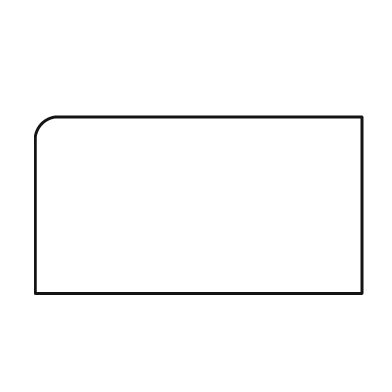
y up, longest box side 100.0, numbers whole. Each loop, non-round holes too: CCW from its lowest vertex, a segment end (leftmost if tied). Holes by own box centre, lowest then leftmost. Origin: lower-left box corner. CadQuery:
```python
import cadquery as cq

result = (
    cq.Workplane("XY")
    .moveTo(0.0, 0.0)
    .lineTo(100.0, 0.0)
    .lineTo(100.0, 54.0)
    .lineTo(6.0, 54.0)
    .threePointArc((2.0, 52.0), (0.0, 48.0))
    .close()
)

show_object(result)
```